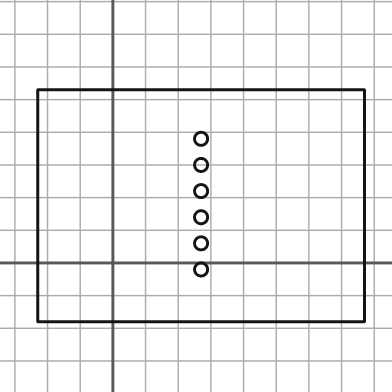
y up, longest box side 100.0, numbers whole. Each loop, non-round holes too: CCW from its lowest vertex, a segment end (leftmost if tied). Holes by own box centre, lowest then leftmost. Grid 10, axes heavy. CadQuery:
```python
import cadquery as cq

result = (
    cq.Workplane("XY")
    .moveTo(-23.0, -18.0)
    .lineTo(77.0, -18.0)
    .lineTo(77.0, 53.0)
    .lineTo(-23.0, 53.0)
    .close()
    .moveTo(27.0, -2.0)
    .circle(2.0)
    .moveTo(27.0, 6.0)
    .circle(2.0)
    .moveTo(27.0, 14.0)
    .circle(2.0)
    .moveTo(27.0, 22.0)
    .circle(2.0)
    .moveTo(27.0, 30.0)
    .circle(2.0)
    .moveTo(27.0, 38.0)
    .circle(2.0)
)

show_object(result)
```